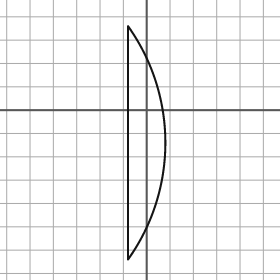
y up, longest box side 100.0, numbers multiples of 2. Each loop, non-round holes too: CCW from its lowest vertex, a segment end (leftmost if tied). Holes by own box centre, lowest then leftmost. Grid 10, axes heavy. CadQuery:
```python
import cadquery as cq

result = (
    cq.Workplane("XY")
    .moveTo(-8.0, -64.0)
    .threePointArc((8.0, -14.0), (-8.0, 36.0))
    .close()
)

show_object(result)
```